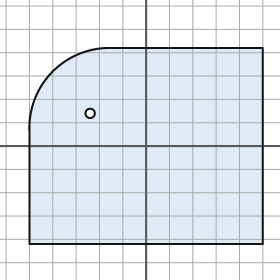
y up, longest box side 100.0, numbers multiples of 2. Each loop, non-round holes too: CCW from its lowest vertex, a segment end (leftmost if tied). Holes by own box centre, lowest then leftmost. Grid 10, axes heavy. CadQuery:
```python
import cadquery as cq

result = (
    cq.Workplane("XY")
    .moveTo(-50.0, -42.0)
    .lineTo(50.0, -42.0)
    .lineTo(50.0, 42.0)
    .lineTo(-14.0, 42.0)
    .threePointArc((-40.0, 32.0), (-50.0, 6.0))
    .close()
    .moveTo(-24.0, 14.0)
    .circle(2.0)
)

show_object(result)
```